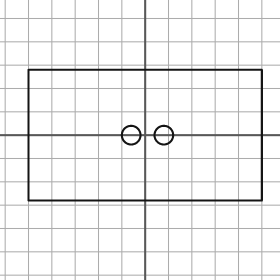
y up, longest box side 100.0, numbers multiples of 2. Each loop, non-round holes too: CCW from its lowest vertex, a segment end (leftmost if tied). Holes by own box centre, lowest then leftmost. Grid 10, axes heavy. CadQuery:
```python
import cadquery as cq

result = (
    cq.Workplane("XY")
    .moveTo(-50.0, -28.0)
    .lineTo(50.0, -28.0)
    .lineTo(50.0, 28.0)
    .lineTo(-50.0, 28.0)
    .close()
    .moveTo(-6.0, 0.0)
    .circle(4.0)
    .moveTo(8.0, 0.0)
    .circle(4.0)
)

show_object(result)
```